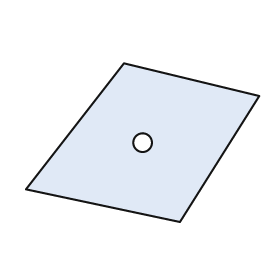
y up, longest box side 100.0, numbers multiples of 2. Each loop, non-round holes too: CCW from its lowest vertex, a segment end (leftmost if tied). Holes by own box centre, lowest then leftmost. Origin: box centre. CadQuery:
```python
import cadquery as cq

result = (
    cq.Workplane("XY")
    .moveTo(16.0, -34.0)
    .lineTo(50.0, 20.0)
    .lineTo(-8.0, 34.0)
    .lineTo(-50.0, -20.0)
    .close()
    .moveTo(0.0, 0.0)
    .circle(4.0)
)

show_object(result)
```